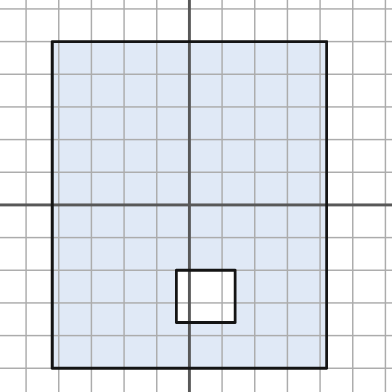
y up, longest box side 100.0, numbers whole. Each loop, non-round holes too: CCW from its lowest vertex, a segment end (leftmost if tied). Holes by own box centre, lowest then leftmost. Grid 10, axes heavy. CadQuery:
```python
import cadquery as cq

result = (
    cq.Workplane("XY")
    .moveTo(-42.0, -50.0)
    .lineTo(42.0, -50.0)
    .lineTo(42.0, 50.0)
    .lineTo(-42.0, 50.0)
    .close()
    .moveTo(-4.0, -36.0)
    .lineTo(14.0, -36.0)
    .lineTo(14.0, -20.0)
    .lineTo(-4.0, -20.0)
    .close()
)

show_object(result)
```